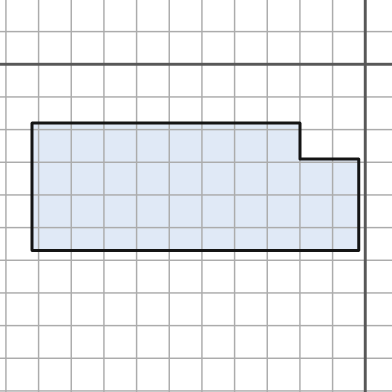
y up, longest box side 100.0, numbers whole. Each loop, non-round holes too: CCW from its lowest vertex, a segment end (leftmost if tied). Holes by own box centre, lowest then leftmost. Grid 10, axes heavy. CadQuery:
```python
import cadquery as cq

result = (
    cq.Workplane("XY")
    .moveTo(-102.0, -57.0)
    .lineTo(-2.0, -57.0)
    .lineTo(-2.0, -29.0)
    .lineTo(-20.0, -29.0)
    .lineTo(-20.0, -18.0)
    .lineTo(-102.0, -18.0)
    .close()
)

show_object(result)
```